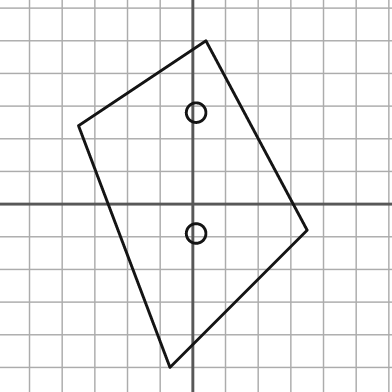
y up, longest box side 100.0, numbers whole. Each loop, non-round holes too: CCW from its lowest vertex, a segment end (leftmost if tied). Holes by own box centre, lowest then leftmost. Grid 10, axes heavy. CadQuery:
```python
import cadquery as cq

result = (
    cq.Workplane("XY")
    .moveTo(-7.0, -50.0)
    .lineTo(35.0, -8.0)
    .lineTo(4.0, 50.0)
    .lineTo(-35.0, 24.0)
    .close()
    .moveTo(1.0, -9.0)
    .circle(3.0)
    .moveTo(1.0, 28.0)
    .circle(3.0)
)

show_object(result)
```